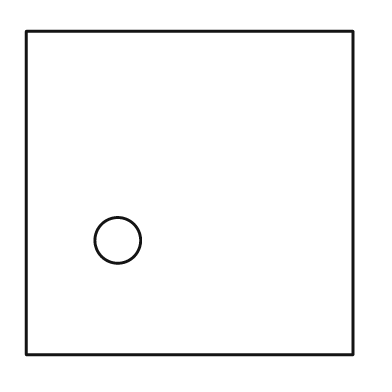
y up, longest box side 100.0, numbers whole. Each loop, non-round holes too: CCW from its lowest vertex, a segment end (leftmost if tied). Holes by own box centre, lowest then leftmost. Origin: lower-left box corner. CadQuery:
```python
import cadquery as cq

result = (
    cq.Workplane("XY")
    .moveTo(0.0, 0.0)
    .lineTo(100.0, 0.0)
    .lineTo(100.0, 99.0)
    .lineTo(0.0, 99.0)
    .close()
    .moveTo(28.0, 35.0)
    .circle(7.0)
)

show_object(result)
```